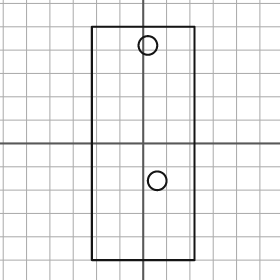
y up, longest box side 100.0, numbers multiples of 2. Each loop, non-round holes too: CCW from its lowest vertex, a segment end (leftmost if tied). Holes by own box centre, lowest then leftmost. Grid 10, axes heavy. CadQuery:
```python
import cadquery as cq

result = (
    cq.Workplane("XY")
    .moveTo(-22.0, -50.0)
    .lineTo(22.0, -50.0)
    .lineTo(22.0, 50.0)
    .lineTo(-22.0, 50.0)
    .close()
    .moveTo(6.0, -16.0)
    .circle(4.0)
    .moveTo(2.0, 42.0)
    .circle(4.0)
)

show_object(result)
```